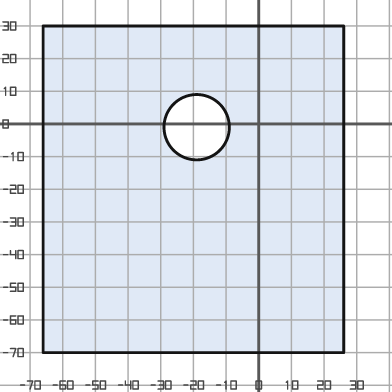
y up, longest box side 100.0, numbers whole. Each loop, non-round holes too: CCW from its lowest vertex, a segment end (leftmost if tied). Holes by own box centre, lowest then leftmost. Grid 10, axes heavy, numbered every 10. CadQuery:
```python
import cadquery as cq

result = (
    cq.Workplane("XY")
    .moveTo(-66.0, -70.0)
    .lineTo(26.0, -70.0)
    .lineTo(26.0, 30.0)
    .lineTo(-66.0, 30.0)
    .close()
    .moveTo(-19.0, -1.0)
    .circle(10.0)
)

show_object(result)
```